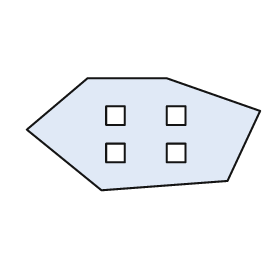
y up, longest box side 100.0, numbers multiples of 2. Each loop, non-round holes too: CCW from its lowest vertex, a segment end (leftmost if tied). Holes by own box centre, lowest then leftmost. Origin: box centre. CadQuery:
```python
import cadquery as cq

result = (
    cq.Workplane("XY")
    .moveTo(-18.0, -24.0)
    .lineTo(36.0, -20.0)
    .lineTo(50.0, 10.0)
    .lineTo(10.0, 24.0)
    .lineTo(-24.0, 24.0)
    .lineTo(-50.0, 2.0)
    .close()
    .moveTo(-16.0, -12.0)
    .lineTo(-8.0, -12.0)
    .lineTo(-8.0, -4.0)
    .lineTo(-16.0, -4.0)
    .close()
    .moveTo(10.0, -12.0)
    .lineTo(18.0, -12.0)
    .lineTo(18.0, -4.0)
    .lineTo(10.0, -4.0)
    .close()
    .moveTo(-16.0, 4.0)
    .lineTo(-8.0, 4.0)
    .lineTo(-8.0, 12.0)
    .lineTo(-16.0, 12.0)
    .close()
    .moveTo(10.0, 4.0)
    .lineTo(18.0, 4.0)
    .lineTo(18.0, 12.0)
    .lineTo(10.0, 12.0)
    .close()
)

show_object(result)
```